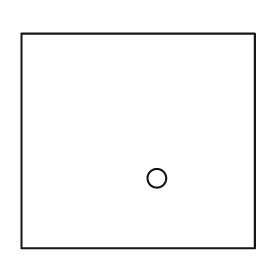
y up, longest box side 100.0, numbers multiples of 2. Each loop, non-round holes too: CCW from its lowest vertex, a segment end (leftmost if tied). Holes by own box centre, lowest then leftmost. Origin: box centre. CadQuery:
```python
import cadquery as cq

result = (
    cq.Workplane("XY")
    .moveTo(-50.0, -46.0)
    .lineTo(50.0, -46.0)
    .lineTo(50.0, 46.0)
    .lineTo(-50.0, 46.0)
    .close()
    .moveTo(8.0, -16.0)
    .circle(4.0)
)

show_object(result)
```